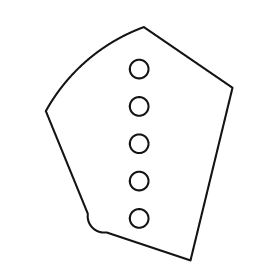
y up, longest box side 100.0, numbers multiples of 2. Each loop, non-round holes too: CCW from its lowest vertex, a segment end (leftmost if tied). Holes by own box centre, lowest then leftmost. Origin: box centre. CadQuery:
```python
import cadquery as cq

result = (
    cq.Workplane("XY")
    .moveTo(22.0, -50.0)
    .lineTo(40.0, 24.0)
    .lineTo(2.0, 50.0)
    .threePointArc((-22.0, 36.0), (-40.0, 14.0))
    .lineTo(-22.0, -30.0)
    .threePointArc((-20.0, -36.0), (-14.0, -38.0))
    .close()
    .moveTo(0.0, -32.0)
    .circle(4.0)
    .moveTo(0.0, -16.0)
    .circle(4.0)
    .moveTo(0.0, 0.0)
    .circle(4.0)
    .moveTo(0.0, 16.0)
    .circle(4.0)
    .moveTo(0.0, 32.0)
    .circle(4.0)
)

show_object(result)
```